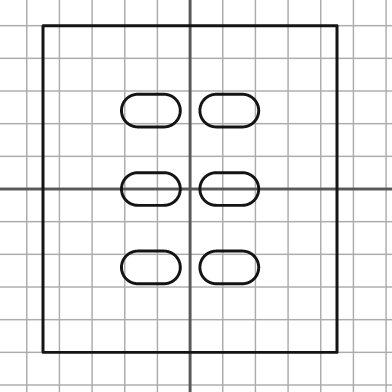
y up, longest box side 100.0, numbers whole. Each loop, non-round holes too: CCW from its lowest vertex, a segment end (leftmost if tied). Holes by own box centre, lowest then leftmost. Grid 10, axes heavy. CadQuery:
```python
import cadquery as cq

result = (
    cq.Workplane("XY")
    .moveTo(-45.0, -50.0)
    .lineTo(45.0, -50.0)
    .lineTo(45.0, 50.0)
    .lineTo(-45.0, 50.0)
    .close()
    .moveTo(-16.0, -29.0)
    .lineTo(-8.0, -29.0)
    .threePointArc((-3.0, -24.0), (-8.0, -19.0))
    .lineTo(-16.0, -19.0)
    .threePointArc((-21.0, -24.0), (-16.0, -29.0))
    .close()
    .moveTo(8.0, -29.0)
    .lineTo(16.0, -29.0)
    .threePointArc((21.0, -24.0), (16.0, -19.0))
    .lineTo(8.0, -19.0)
    .threePointArc((3.0, -24.0), (8.0, -29.0))
    .close()
    .moveTo(-16.0, -5.0)
    .lineTo(-8.0, -5.0)
    .threePointArc((-3.0, 0.0), (-8.0, 5.0))
    .lineTo(-16.0, 5.0)
    .threePointArc((-21.0, 0.0), (-16.0, -5.0))
    .close()
    .moveTo(8.0, -5.0)
    .lineTo(16.0, -5.0)
    .threePointArc((21.0, 0.0), (16.0, 5.0))
    .lineTo(8.0, 5.0)
    .threePointArc((3.0, 0.0), (8.0, -5.0))
    .close()
    .moveTo(-16.0, 19.0)
    .lineTo(-8.0, 19.0)
    .threePointArc((-3.0, 24.0), (-8.0, 29.0))
    .lineTo(-16.0, 29.0)
    .threePointArc((-21.0, 24.0), (-16.0, 19.0))
    .close()
    .moveTo(8.0, 19.0)
    .lineTo(16.0, 19.0)
    .threePointArc((21.0, 24.0), (16.0, 29.0))
    .lineTo(8.0, 29.0)
    .threePointArc((3.0, 24.0), (8.0, 19.0))
    .close()
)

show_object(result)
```